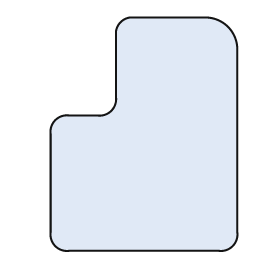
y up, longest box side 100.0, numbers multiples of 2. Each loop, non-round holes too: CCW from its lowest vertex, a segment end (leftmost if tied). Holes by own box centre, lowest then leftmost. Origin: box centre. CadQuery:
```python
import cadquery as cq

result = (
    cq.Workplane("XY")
    .moveTo(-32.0, -50.0)
    .lineTo(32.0, -50.0)
    .threePointArc((38.0, -48.0), (40.0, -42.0))
    .lineTo(40.0, 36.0)
    .threePointArc((36.0, 46.0), (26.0, 50.0))
    .lineTo(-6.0, 50.0)
    .threePointArc((-10.0, 48.0), (-12.0, 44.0))
    .lineTo(-12.0, 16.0)
    .threePointArc((-14.0, 10.0), (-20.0, 8.0))
    .lineTo(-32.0, 8.0)
    .threePointArc((-38.0, 6.0), (-40.0, 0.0))
    .lineTo(-40.0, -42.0)
    .threePointArc((-38.0, -48.0), (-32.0, -50.0))
    .close()
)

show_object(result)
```